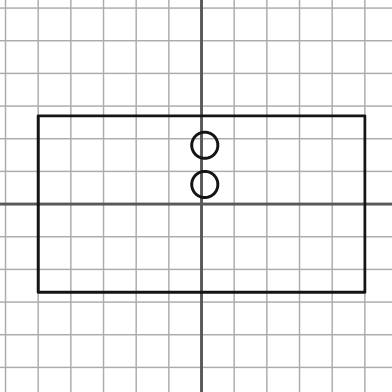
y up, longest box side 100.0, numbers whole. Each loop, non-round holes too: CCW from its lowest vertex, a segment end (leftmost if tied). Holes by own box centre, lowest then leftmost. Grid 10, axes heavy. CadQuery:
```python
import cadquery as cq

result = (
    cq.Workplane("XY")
    .moveTo(-50.0, -27.0)
    .lineTo(50.0, -27.0)
    .lineTo(50.0, 27.0)
    .lineTo(-50.0, 27.0)
    .close()
    .moveTo(1.0, 6.0)
    .circle(4.0)
    .moveTo(1.0, 18.0)
    .circle(4.0)
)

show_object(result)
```